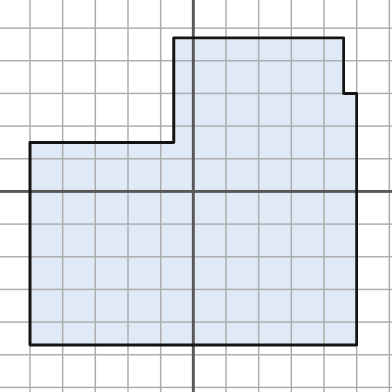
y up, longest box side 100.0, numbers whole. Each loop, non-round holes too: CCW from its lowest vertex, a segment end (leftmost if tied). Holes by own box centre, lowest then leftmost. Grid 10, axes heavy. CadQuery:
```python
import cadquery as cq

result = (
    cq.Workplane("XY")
    .moveTo(-50.0, -47.0)
    .lineTo(50.0, -47.0)
    .lineTo(50.0, 30.0)
    .lineTo(46.0, 30.0)
    .lineTo(46.0, 47.0)
    .lineTo(-6.0, 47.0)
    .lineTo(-6.0, 15.0)
    .lineTo(-50.0, 15.0)
    .close()
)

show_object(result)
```